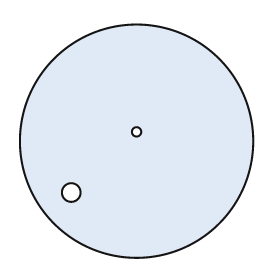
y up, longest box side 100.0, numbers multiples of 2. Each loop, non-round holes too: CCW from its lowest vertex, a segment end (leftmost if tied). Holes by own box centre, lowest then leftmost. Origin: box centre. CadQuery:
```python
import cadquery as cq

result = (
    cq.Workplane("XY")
    .moveTo(0.0, 0.0)
    .circle(50.0)
    .moveTo(-28.0, -22.0)
    .circle(4.0)
    .moveTo(0.0, 4.0)
    .circle(2.0)
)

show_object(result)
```